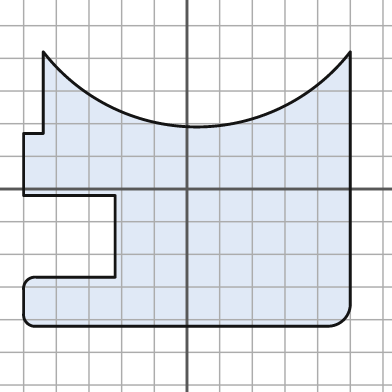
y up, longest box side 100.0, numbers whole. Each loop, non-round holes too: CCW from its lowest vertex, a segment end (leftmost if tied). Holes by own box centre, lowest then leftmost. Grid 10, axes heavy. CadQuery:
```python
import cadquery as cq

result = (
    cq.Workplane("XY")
    .moveTo(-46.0, -42.0)
    .lineTo(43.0, -42.0)
    .threePointArc((48.0, -40.0), (50.0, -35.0))
    .lineTo(50.0, 42.0)
    .threePointArc((3.0, 19.0), (-44.0, 42.0))
    .lineTo(-44.0, 17.0)
    .lineTo(-50.0, 17.0)
    .lineTo(-50.0, -2.0)
    .lineTo(-22.0, -2.0)
    .lineTo(-22.0, -27.0)
    .lineTo(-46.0, -27.0)
    .threePointArc((-49.0, -28.0), (-50.0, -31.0))
    .lineTo(-50.0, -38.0)
    .threePointArc((-49.0, -41.0), (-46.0, -42.0))
    .close()
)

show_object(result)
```